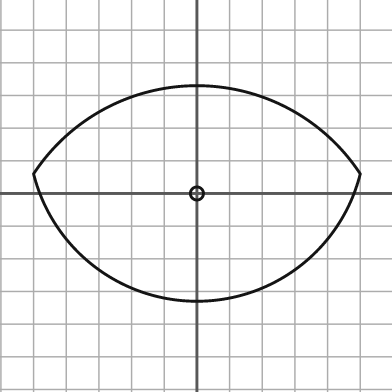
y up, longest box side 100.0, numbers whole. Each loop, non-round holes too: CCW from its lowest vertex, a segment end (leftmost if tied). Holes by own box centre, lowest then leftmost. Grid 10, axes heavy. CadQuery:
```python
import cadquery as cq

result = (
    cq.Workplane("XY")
    .moveTo(-50.0, 6.0)
    .threePointArc((0.0, -33.0), (50.0, 6.0))
    .threePointArc((0.0, 33.0), (-50.0, 6.0))
    .close()
    .moveTo(0.0, 0.0)
    .circle(2.0)
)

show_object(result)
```